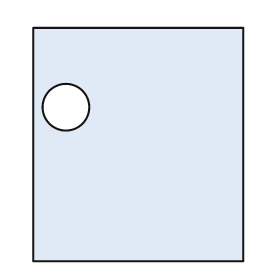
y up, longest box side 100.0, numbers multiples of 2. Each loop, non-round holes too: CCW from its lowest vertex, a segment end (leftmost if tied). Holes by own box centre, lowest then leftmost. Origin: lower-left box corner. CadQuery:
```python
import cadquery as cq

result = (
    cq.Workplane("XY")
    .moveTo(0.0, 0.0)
    .lineTo(90.0, 0.0)
    .lineTo(90.0, 100.0)
    .lineTo(0.0, 100.0)
    .close()
    .moveTo(14.0, 66.0)
    .circle(10.0)
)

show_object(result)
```